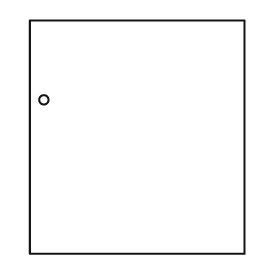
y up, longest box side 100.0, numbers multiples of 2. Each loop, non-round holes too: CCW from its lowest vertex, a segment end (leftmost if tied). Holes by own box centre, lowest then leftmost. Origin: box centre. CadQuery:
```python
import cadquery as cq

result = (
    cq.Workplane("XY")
    .moveTo(-46.0, -50.0)
    .lineTo(46.0, -50.0)
    .lineTo(46.0, 50.0)
    .lineTo(-46.0, 50.0)
    .close()
    .moveTo(-40.0, 16.0)
    .circle(2.0)
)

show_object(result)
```